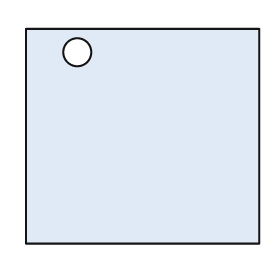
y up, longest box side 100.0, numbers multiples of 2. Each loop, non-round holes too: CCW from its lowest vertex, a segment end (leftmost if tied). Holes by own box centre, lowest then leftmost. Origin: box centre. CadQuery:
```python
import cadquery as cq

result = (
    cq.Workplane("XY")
    .moveTo(-50.0, -46.0)
    .lineTo(50.0, -46.0)
    .lineTo(50.0, 46.0)
    .lineTo(-50.0, 46.0)
    .close()
    .moveTo(-28.0, 36.0)
    .circle(6.0)
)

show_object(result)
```